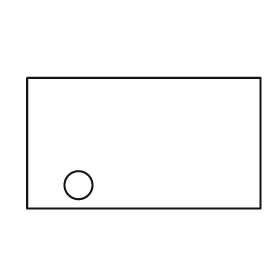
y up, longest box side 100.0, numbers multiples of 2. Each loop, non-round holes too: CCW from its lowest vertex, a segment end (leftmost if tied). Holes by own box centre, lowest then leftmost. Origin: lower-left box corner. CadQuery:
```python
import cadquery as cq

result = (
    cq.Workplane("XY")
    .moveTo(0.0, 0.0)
    .lineTo(100.0, 0.0)
    .lineTo(100.0, 56.0)
    .lineTo(0.0, 56.0)
    .close()
    .moveTo(22.0, 10.0)
    .circle(6.0)
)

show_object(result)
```